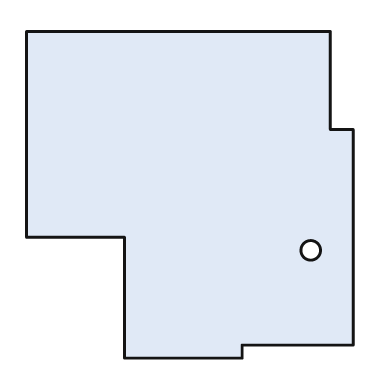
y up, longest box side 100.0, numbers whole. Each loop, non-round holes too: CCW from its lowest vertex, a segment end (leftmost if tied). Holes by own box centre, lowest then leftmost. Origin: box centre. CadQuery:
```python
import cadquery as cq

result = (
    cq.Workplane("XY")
    .moveTo(-20.0, -50.0)
    .lineTo(16.0, -50.0)
    .lineTo(16.0, -46.0)
    .lineTo(50.0, -46.0)
    .lineTo(50.0, 20.0)
    .lineTo(43.0, 20.0)
    .lineTo(43.0, 50.0)
    .lineTo(-50.0, 50.0)
    .lineTo(-50.0, -13.0)
    .lineTo(-20.0, -13.0)
    .close()
    .moveTo(37.0, -17.0)
    .circle(3.0)
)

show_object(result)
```